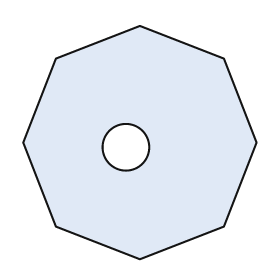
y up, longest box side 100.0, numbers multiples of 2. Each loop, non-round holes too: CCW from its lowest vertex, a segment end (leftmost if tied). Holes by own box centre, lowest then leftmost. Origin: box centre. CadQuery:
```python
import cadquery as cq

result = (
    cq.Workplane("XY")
    .moveTo(0.0, -50.0)
    .lineTo(36.0, -36.0)
    .lineTo(50.0, 0.0)
    .lineTo(36.0, 36.0)
    .lineTo(0.0, 50.0)
    .lineTo(-36.0, 36.0)
    .lineTo(-50.0, 0.0)
    .lineTo(-36.0, -36.0)
    .close()
    .moveTo(-6.0, -2.0)
    .circle(10.0)
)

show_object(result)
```